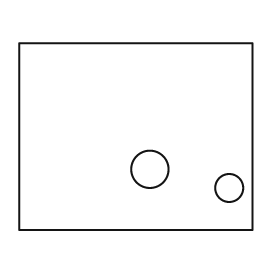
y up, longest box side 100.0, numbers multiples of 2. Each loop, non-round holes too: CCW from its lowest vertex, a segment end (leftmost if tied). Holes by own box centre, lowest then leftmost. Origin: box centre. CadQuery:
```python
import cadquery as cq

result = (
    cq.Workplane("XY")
    .moveTo(-50.0, -40.0)
    .lineTo(50.0, -40.0)
    .lineTo(50.0, 40.0)
    .lineTo(-50.0, 40.0)
    .close()
    .moveTo(40.0, -22.0)
    .circle(6.0)
    .moveTo(6.0, -14.0)
    .circle(8.0)
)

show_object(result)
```